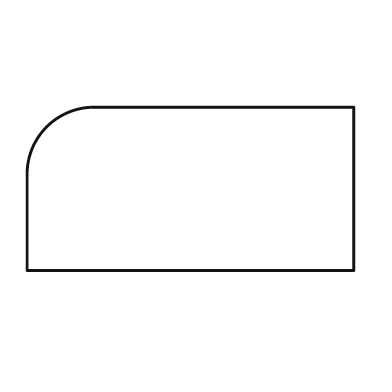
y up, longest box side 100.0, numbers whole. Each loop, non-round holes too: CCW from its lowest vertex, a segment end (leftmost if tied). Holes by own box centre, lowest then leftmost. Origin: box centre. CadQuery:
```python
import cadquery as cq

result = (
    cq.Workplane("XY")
    .moveTo(-50.0, -25.0)
    .lineTo(50.0, -25.0)
    .lineTo(50.0, 25.0)
    .lineTo(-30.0, 25.0)
    .threePointArc((-44.0, 19.0), (-50.0, 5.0))
    .close()
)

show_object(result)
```